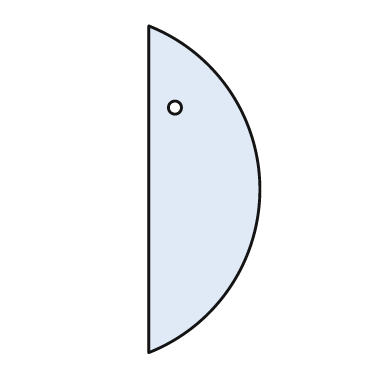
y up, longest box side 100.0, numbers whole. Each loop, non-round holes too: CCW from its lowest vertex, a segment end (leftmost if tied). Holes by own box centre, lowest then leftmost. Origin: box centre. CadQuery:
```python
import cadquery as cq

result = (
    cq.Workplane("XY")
    .moveTo(-17.0, -50.0)
    .threePointArc((17.0, 0.0), (-17.0, 50.0))
    .close()
    .moveTo(-9.0, 25.0)
    .circle(2.0)
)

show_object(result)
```